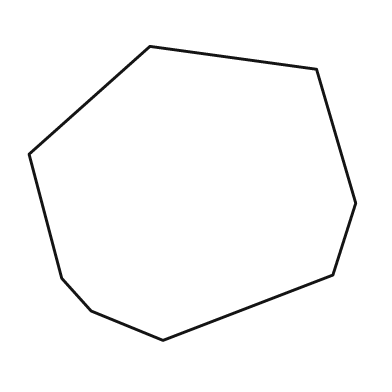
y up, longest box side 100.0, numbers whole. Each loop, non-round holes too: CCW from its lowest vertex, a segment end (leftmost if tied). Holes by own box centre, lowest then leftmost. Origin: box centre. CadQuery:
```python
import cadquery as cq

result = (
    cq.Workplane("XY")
    .moveTo(-9.0, -45.0)
    .lineTo(43.0, -25.0)
    .lineTo(50.0, -3.0)
    .lineTo(38.0, 38.0)
    .lineTo(-13.0, 45.0)
    .lineTo(-50.0, 12.0)
    .lineTo(-40.0, -26.0)
    .lineTo(-31.0, -36.0)
    .close()
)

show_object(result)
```